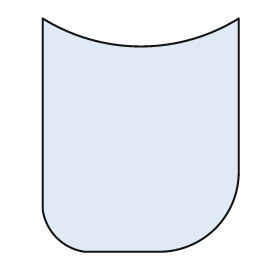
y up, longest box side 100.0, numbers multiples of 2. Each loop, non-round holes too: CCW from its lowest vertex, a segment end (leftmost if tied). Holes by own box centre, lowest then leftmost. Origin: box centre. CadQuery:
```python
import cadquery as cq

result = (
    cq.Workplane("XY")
    .moveTo(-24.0, -50.0)
    .lineTo(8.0, -50.0)
    .threePointArc((32.0, -40.0), (42.0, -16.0))
    .lineTo(42.0, 50.0)
    .threePointArc((0.0, 38.0), (-42.0, 50.0))
    .lineTo(-42.0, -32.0)
    .threePointArc((-36.0, -44.0), (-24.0, -50.0))
    .close()
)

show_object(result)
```